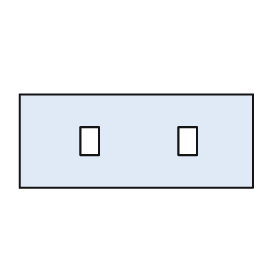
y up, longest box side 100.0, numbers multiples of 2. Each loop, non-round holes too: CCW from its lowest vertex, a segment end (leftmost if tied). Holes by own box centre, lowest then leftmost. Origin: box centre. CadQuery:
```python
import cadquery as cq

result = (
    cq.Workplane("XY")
    .moveTo(-50.0, -20.0)
    .lineTo(50.0, -20.0)
    .lineTo(50.0, 20.0)
    .lineTo(-50.0, 20.0)
    .close()
    .moveTo(-24.0, -6.0)
    .lineTo(-16.0, -6.0)
    .lineTo(-16.0, 6.0)
    .lineTo(-24.0, 6.0)
    .close()
    .moveTo(18.0, -6.0)
    .lineTo(26.0, -6.0)
    .lineTo(26.0, 6.0)
    .lineTo(18.0, 6.0)
    .close()
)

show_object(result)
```